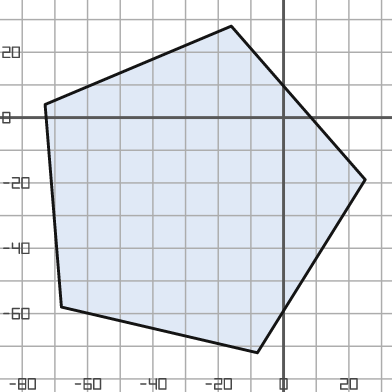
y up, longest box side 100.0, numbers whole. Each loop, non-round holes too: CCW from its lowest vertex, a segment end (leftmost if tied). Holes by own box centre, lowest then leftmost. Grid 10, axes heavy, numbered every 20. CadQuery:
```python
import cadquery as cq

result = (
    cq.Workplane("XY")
    .moveTo(-8.0, -72.0)
    .lineTo(25.0, -19.0)
    .lineTo(-16.0, 28.0)
    .lineTo(-73.0, 4.0)
    .lineTo(-68.0, -58.0)
    .close()
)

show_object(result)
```